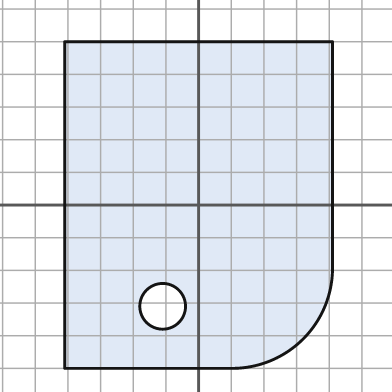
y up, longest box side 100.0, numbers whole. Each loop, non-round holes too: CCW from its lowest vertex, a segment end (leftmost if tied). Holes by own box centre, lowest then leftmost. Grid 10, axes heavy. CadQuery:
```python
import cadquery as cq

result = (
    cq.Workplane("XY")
    .moveTo(-41.0, -50.0)
    .lineTo(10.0, -50.0)
    .threePointArc((32.0, -41.0), (41.0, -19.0))
    .lineTo(41.0, 50.0)
    .lineTo(-41.0, 50.0)
    .close()
    .moveTo(-11.0, -31.0)
    .circle(7.0)
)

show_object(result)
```